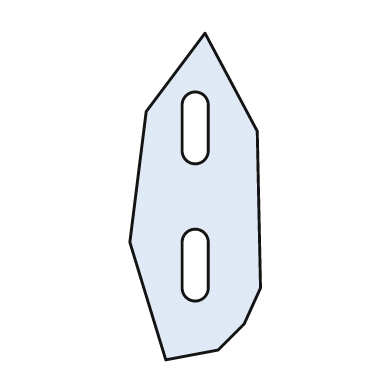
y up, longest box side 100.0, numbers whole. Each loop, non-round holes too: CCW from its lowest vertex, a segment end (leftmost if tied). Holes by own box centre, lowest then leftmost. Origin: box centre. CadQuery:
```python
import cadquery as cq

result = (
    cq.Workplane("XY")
    .moveTo(-9.0, -50.0)
    .lineTo(7.0, -47.0)
    .lineTo(15.0, -39.0)
    .lineTo(20.0, -28.0)
    .lineTo(19.0, 20.0)
    .lineTo(3.0, 50.0)
    .lineTo(-15.0, 26.0)
    .lineTo(-20.0, -14.0)
    .close()
    .moveTo(-4.0, -28.0)
    .threePointArc((0.0, -32.0), (4.0, -28.0))
    .lineTo(4.0, -14.0)
    .threePointArc((0.0, -10.0), (-4.0, -14.0))
    .close()
    .moveTo(-4.0, 14.0)
    .threePointArc((0.0, 10.0), (4.0, 14.0))
    .lineTo(4.0, 28.0)
    .threePointArc((0.0, 32.0), (-4.0, 28.0))
    .close()
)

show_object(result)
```